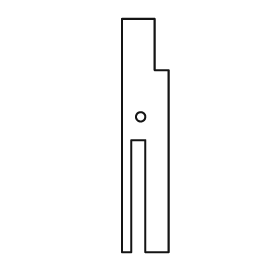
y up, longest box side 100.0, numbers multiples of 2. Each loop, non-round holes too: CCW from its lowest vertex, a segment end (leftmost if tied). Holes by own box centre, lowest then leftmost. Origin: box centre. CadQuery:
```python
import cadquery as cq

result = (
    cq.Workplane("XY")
    .moveTo(-10.0, -50.0)
    .lineTo(-6.0, -50.0)
    .lineTo(-6.0, -2.0)
    .lineTo(0.0, -2.0)
    .lineTo(0.0, -50.0)
    .lineTo(10.0, -50.0)
    .lineTo(10.0, 28.0)
    .lineTo(4.0, 28.0)
    .lineTo(4.0, 50.0)
    .lineTo(-10.0, 50.0)
    .close()
    .moveTo(-2.0, 8.0)
    .circle(2.0)
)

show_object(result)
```